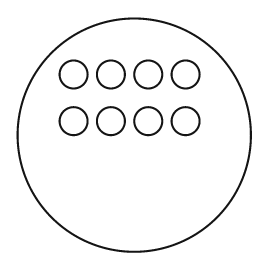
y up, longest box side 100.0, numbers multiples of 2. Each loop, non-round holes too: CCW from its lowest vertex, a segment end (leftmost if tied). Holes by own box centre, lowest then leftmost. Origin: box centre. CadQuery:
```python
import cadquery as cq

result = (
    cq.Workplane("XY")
    .moveTo(0.0, 0.0)
    .circle(50.0)
    .moveTo(-26.0, 6.0)
    .circle(6.0)
    .moveTo(-10.0, 6.0)
    .circle(6.0)
    .moveTo(6.0, 6.0)
    .circle(6.0)
    .moveTo(22.0, 6.0)
    .circle(6.0)
    .moveTo(-26.0, 26.0)
    .circle(6.0)
    .moveTo(-10.0, 26.0)
    .circle(6.0)
    .moveTo(6.0, 26.0)
    .circle(6.0)
    .moveTo(22.0, 26.0)
    .circle(6.0)
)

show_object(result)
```